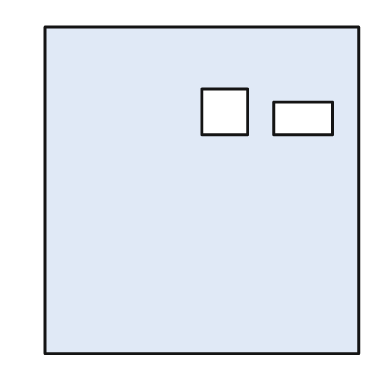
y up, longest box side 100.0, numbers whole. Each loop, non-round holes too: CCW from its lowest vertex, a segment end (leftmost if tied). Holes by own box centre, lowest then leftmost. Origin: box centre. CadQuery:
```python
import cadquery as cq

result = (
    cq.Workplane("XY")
    .moveTo(-48.0, -50.0)
    .lineTo(48.0, -50.0)
    .lineTo(48.0, 50.0)
    .lineTo(-48.0, 50.0)
    .close()
    .moveTo(22.0, 17.0)
    .lineTo(40.0, 17.0)
    .lineTo(40.0, 27.0)
    .lineTo(22.0, 27.0)
    .close()
    .moveTo(0.0, 17.0)
    .lineTo(14.0, 17.0)
    .lineTo(14.0, 31.0)
    .lineTo(0.0, 31.0)
    .close()
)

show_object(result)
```